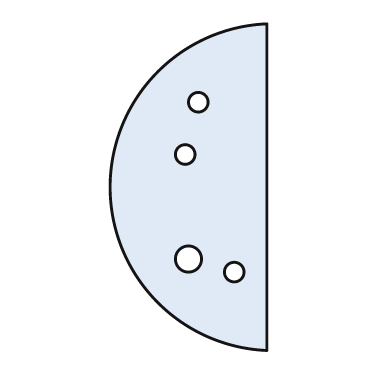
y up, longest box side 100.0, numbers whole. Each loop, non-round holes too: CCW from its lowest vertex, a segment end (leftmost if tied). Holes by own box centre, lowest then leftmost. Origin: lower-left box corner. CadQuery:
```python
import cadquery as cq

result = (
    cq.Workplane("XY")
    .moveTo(48.0, 0.0)
    .lineTo(48.0, 100.0)
    .threePointArc((0.0, 50.0), (48.0, 0.0))
    .close()
    .moveTo(38.0, 24.0)
    .circle(3.0)
    .moveTo(24.0, 28.0)
    .circle(4.0)
    .moveTo(23.0, 60.0)
    .circle(3.0)
    .moveTo(27.0, 76.0)
    .circle(3.0)
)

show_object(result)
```